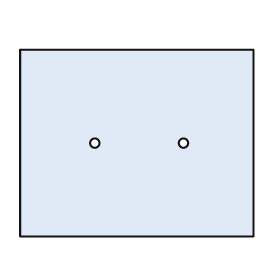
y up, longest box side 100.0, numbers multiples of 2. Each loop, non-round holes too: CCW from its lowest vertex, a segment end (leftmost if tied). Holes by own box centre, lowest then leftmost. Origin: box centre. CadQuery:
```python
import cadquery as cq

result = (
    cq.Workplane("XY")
    .moveTo(-50.0, -40.0)
    .lineTo(50.0, -40.0)
    .lineTo(50.0, 40.0)
    .lineTo(-50.0, 40.0)
    .close()
    .moveTo(-18.0, 0.0)
    .circle(2.0)
    .moveTo(20.0, 0.0)
    .circle(2.0)
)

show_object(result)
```